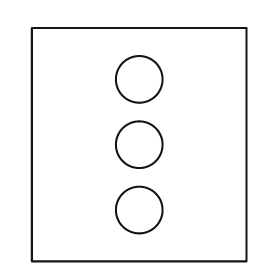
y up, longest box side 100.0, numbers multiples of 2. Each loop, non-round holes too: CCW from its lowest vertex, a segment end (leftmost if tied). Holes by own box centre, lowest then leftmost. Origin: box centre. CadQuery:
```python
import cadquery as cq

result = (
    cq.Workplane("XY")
    .moveTo(-46.0, -50.0)
    .lineTo(46.0, -50.0)
    .lineTo(46.0, 50.0)
    .lineTo(-46.0, 50.0)
    .close()
    .moveTo(0.0, -28.0)
    .circle(10.0)
    .moveTo(0.0, 0.0)
    .circle(10.0)
    .moveTo(0.0, 28.0)
    .circle(10.0)
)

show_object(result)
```